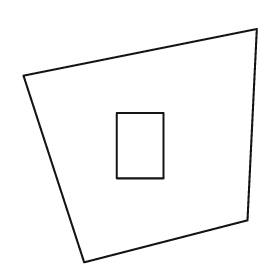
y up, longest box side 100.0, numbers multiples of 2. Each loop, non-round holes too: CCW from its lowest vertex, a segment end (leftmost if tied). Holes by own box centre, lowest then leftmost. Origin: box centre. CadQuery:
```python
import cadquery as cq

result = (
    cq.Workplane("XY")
    .moveTo(-24.0, -50.0)
    .lineTo(46.0, -32.0)
    .lineTo(50.0, 50.0)
    .lineTo(-50.0, 30.0)
    .close()
    .moveTo(-10.0, -14.0)
    .lineTo(10.0, -14.0)
    .lineTo(10.0, 14.0)
    .lineTo(-10.0, 14.0)
    .close()
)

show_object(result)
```